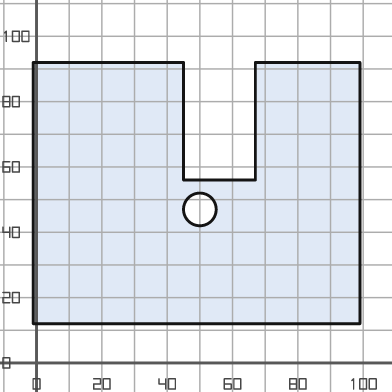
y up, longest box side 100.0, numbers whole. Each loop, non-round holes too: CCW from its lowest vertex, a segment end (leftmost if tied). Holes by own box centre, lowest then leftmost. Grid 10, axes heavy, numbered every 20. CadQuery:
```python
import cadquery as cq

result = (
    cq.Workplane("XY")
    .moveTo(-1.0, 12.0)
    .lineTo(99.0, 12.0)
    .lineTo(99.0, 92.0)
    .lineTo(67.0, 92.0)
    .lineTo(67.0, 56.0)
    .lineTo(45.0, 56.0)
    .lineTo(45.0, 92.0)
    .lineTo(-1.0, 92.0)
    .close()
    .moveTo(50.0, 47.0)
    .circle(5.0)
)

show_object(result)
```